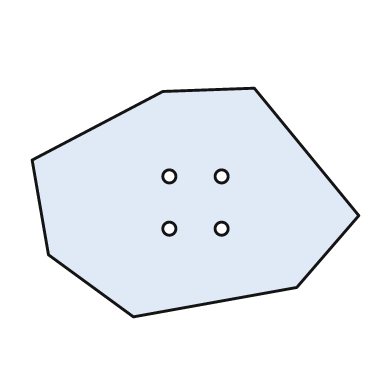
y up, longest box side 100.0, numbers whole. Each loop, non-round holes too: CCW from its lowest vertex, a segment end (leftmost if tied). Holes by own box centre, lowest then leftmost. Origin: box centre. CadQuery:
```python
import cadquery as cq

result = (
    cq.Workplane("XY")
    .moveTo(-19.0, -35.0)
    .lineTo(31.0, -26.0)
    .lineTo(50.0, -4.0)
    .lineTo(18.0, 35.0)
    .lineTo(-10.0, 34.0)
    .lineTo(-50.0, 13.0)
    .lineTo(-45.0, -16.0)
    .close()
    .moveTo(-8.0, -8.0)
    .circle(2.0)
    .moveTo(8.0, -8.0)
    .circle(2.0)
    .moveTo(-8.0, 8.0)
    .circle(2.0)
    .moveTo(8.0, 8.0)
    .circle(2.0)
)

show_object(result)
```